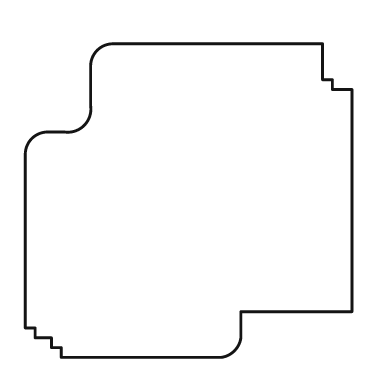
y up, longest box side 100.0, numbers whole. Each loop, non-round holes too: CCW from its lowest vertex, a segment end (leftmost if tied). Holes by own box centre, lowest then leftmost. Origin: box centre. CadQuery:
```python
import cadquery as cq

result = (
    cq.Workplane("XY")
    .moveTo(-39.0, -48.0)
    .lineTo(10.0, -48.0)
    .threePointArc((14.0, -46.0), (16.0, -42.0))
    .lineTo(16.0, -34.0)
    .lineTo(50.0, -34.0)
    .lineTo(50.0, 34.0)
    .lineTo(44.0, 34.0)
    .lineTo(44.0, 37.0)
    .lineTo(41.0, 37.0)
    .lineTo(41.0, 48.0)
    .lineTo(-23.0, 48.0)
    .threePointArc((-28.0, 46.0), (-30.0, 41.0))
    .lineTo(-30.0, 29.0)
    .threePointArc((-32.0, 23.0), (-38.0, 21.0))
    .lineTo(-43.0, 21.0)
    .threePointArc((-48.0, 19.0), (-50.0, 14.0))
    .lineTo(-50.0, -39.0)
    .lineTo(-47.0, -39.0)
    .lineTo(-47.0, -42.0)
    .lineTo(-42.0, -42.0)
    .lineTo(-42.0, -45.0)
    .lineTo(-39.0, -45.0)
    .close()
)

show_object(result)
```